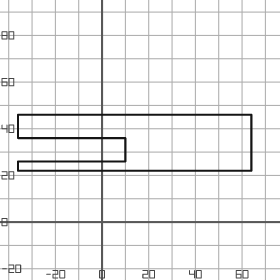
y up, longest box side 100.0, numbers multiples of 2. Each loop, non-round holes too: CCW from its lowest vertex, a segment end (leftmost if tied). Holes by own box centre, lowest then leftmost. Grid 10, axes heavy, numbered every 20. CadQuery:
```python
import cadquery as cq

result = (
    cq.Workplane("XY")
    .moveTo(-36.0, 22.0)
    .lineTo(64.0, 22.0)
    .lineTo(64.0, 46.0)
    .lineTo(-36.0, 46.0)
    .lineTo(-36.0, 36.0)
    .lineTo(10.0, 36.0)
    .lineTo(10.0, 26.0)
    .lineTo(-36.0, 26.0)
    .close()
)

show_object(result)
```